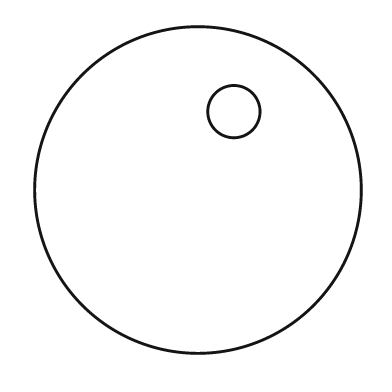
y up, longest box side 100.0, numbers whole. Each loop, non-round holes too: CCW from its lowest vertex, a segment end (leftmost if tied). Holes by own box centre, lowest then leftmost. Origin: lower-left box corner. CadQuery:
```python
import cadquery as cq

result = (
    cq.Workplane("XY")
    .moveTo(50.0, 50.0)
    .circle(50.0)
    .moveTo(61.0, 74.0)
    .circle(8.0)
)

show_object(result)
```